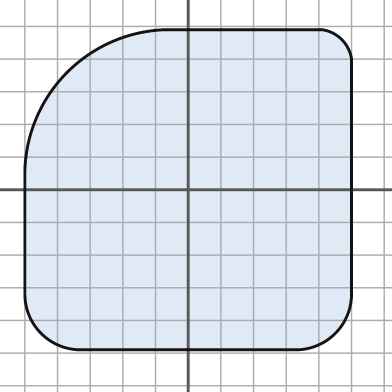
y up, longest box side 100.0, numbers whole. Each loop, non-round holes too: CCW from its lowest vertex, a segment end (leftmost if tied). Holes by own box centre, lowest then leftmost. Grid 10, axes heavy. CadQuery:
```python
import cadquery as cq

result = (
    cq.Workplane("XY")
    .moveTo(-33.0, -49.0)
    .lineTo(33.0, -49.0)
    .threePointArc((45.0, -44.0), (50.0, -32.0))
    .lineTo(50.0, 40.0)
    .threePointArc((47.0, 46.0), (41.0, 49.0))
    .lineTo(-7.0, 49.0)
    .threePointArc((-37.0, 36.0), (-50.0, 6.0))
    .lineTo(-50.0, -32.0)
    .threePointArc((-45.0, -44.0), (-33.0, -49.0))
    .close()
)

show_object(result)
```